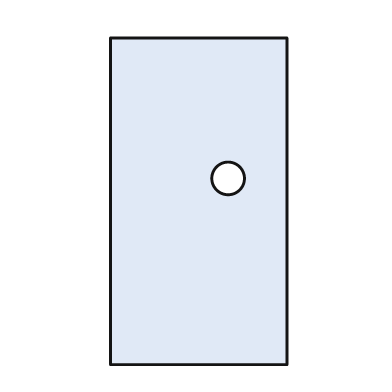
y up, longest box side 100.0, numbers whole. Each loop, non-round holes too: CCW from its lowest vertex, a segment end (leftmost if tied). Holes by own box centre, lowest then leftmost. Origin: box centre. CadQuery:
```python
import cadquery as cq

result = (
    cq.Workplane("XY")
    .moveTo(-27.0, -50.0)
    .lineTo(27.0, -50.0)
    .lineTo(27.0, 50.0)
    .lineTo(-27.0, 50.0)
    .close()
    .moveTo(9.0, 7.0)
    .circle(5.0)
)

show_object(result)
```